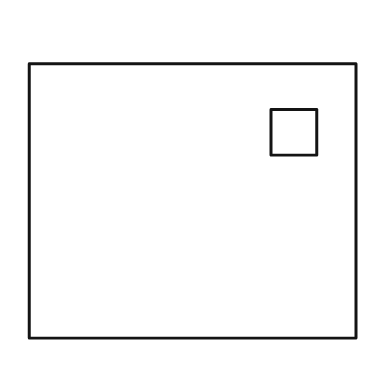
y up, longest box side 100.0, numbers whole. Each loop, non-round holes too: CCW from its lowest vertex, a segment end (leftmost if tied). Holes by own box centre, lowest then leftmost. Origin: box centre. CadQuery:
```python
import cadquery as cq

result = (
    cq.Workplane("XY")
    .moveTo(-50.0, -42.0)
    .lineTo(50.0, -42.0)
    .lineTo(50.0, 42.0)
    .lineTo(-50.0, 42.0)
    .close()
    .moveTo(24.0, 14.0)
    .lineTo(38.0, 14.0)
    .lineTo(38.0, 28.0)
    .lineTo(24.0, 28.0)
    .close()
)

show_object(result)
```